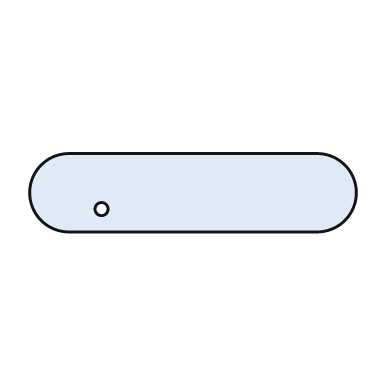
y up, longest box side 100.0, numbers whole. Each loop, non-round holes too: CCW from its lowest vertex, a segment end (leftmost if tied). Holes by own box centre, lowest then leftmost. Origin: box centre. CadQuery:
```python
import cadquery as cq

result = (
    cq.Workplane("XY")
    .moveTo(-38.0, -12.0)
    .lineTo(38.0, -12.0)
    .threePointArc((50.0, 0.0), (38.0, 12.0))
    .lineTo(-38.0, 12.0)
    .threePointArc((-50.0, 0.0), (-38.0, -12.0))
    .close()
    .moveTo(-28.0, -5.0)
    .circle(2.0)
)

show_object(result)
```